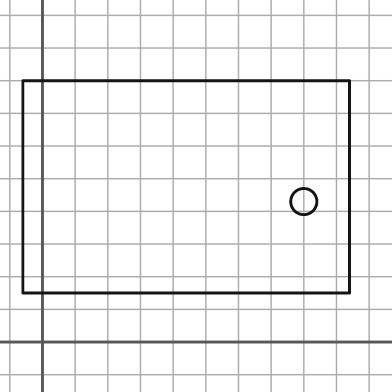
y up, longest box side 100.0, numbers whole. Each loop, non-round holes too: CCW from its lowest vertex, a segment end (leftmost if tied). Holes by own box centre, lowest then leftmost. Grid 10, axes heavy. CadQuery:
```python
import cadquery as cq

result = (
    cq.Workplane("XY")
    .moveTo(-6.0, 15.0)
    .lineTo(94.0, 15.0)
    .lineTo(94.0, 80.0)
    .lineTo(-6.0, 80.0)
    .close()
    .moveTo(80.0, 43.0)
    .circle(4.0)
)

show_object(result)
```